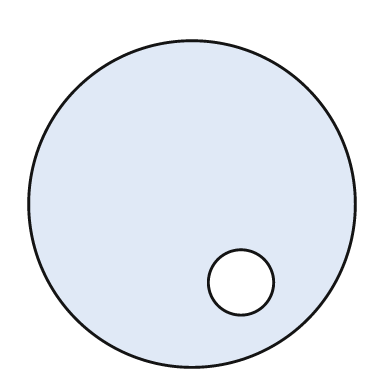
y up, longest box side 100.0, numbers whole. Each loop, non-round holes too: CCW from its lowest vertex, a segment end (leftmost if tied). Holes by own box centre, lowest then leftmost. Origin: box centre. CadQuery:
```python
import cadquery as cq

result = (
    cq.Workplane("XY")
    .moveTo(0.0, 0.0)
    .circle(50.0)
    .moveTo(15.0, -24.0)
    .circle(10.0)
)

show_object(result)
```